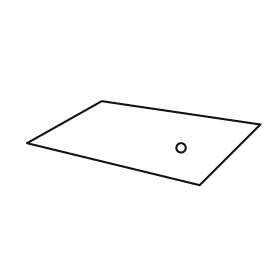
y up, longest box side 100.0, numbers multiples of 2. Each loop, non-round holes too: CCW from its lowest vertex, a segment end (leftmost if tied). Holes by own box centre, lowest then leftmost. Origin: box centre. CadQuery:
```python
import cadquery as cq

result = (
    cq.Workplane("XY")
    .moveTo(24.0, -18.0)
    .lineTo(50.0, 8.0)
    .lineTo(-18.0, 18.0)
    .lineTo(-50.0, 0.0)
    .close()
    .moveTo(16.0, -2.0)
    .circle(2.0)
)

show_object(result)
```